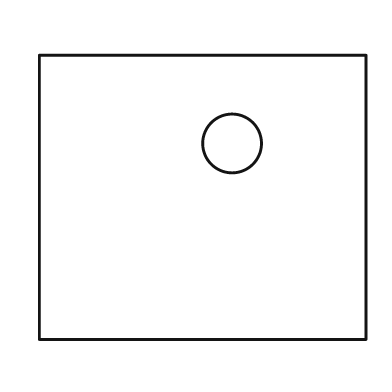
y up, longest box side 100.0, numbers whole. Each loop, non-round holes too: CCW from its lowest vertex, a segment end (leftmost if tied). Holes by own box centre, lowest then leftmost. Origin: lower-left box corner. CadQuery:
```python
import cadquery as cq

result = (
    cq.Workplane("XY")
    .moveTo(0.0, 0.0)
    .lineTo(100.0, 0.0)
    .lineTo(100.0, 87.0)
    .lineTo(0.0, 87.0)
    .close()
    .moveTo(59.0, 60.0)
    .circle(9.0)
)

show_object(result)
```